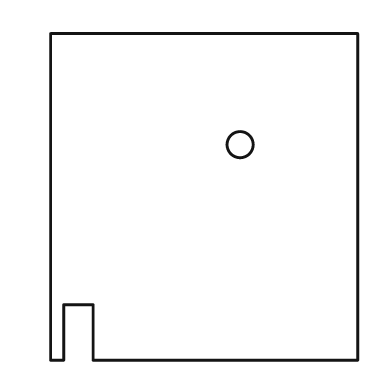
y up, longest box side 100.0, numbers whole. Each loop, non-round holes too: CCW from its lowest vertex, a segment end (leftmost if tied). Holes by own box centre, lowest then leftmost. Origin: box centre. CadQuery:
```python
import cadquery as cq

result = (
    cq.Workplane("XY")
    .moveTo(-47.0, -50.0)
    .lineTo(-43.0, -50.0)
    .lineTo(-43.0, -33.0)
    .lineTo(-34.0, -33.0)
    .lineTo(-34.0, -50.0)
    .lineTo(47.0, -50.0)
    .lineTo(47.0, 50.0)
    .lineTo(-47.0, 50.0)
    .close()
    .moveTo(11.0, 16.0)
    .circle(4.0)
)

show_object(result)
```